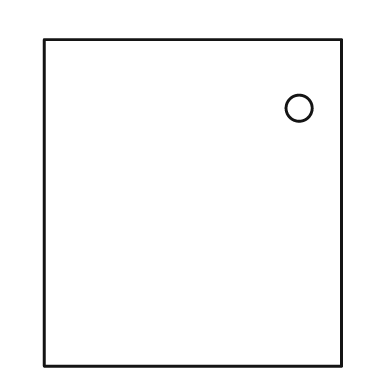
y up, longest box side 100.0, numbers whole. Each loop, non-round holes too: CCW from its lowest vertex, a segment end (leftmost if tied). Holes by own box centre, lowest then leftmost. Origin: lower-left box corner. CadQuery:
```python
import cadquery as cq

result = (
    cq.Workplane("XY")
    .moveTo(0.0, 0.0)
    .lineTo(91.0, 0.0)
    .lineTo(91.0, 100.0)
    .lineTo(0.0, 100.0)
    .close()
    .moveTo(78.0, 79.0)
    .circle(4.0)
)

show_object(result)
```